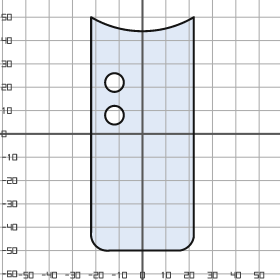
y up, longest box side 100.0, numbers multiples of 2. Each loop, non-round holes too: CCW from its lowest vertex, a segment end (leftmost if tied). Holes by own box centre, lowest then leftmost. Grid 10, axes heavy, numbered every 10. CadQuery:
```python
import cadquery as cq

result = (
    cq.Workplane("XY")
    .moveTo(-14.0, -50.0)
    .lineTo(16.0, -50.0)
    .threePointArc((20.0, -48.0), (22.0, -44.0))
    .lineTo(22.0, 50.0)
    .threePointArc((0.0, 44.0), (-22.0, 50.0))
    .lineTo(-22.0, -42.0)
    .threePointArc((-20.0, -48.0), (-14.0, -50.0))
    .close()
    .moveTo(-12.0, 8.0)
    .circle(4.0)
    .moveTo(-12.0, 22.0)
    .circle(4.0)
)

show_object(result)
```